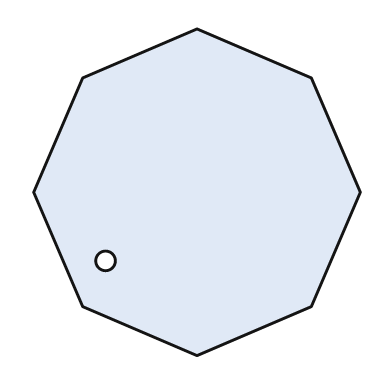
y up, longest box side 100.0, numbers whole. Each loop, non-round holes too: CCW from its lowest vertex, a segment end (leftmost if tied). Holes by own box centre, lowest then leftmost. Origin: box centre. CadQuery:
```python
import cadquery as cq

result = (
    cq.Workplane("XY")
    .moveTo(0.0, -50.0)
    .lineTo(35.0, -35.0)
    .lineTo(50.0, 0.0)
    .lineTo(35.0, 35.0)
    .lineTo(0.0, 50.0)
    .lineTo(-35.0, 35.0)
    .lineTo(-50.0, 0.0)
    .lineTo(-35.0, -35.0)
    .close()
    .moveTo(-28.0, -21.0)
    .circle(3.0)
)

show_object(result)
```